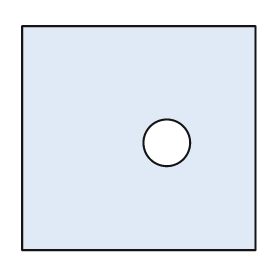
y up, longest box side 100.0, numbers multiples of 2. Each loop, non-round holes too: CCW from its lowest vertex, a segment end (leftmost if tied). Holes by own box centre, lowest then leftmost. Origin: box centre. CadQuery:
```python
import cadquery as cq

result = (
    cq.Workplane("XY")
    .moveTo(-50.0, -48.0)
    .lineTo(50.0, -48.0)
    .lineTo(50.0, 48.0)
    .lineTo(-50.0, 48.0)
    .close()
    .moveTo(12.0, -2.0)
    .circle(10.0)
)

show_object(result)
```